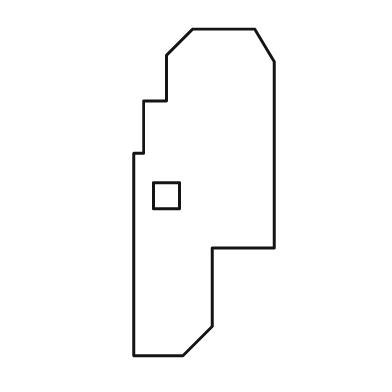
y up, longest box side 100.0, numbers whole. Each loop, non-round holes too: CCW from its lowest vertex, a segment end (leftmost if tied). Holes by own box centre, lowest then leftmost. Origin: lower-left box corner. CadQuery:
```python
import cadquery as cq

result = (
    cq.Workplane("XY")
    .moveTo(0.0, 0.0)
    .lineTo(15.0, 0.0)
    .lineTo(24.0, 9.0)
    .lineTo(24.0, 33.0)
    .lineTo(43.0, 33.0)
    .lineTo(43.0, 90.0)
    .lineTo(37.0, 100.0)
    .lineTo(18.0, 100.0)
    .lineTo(10.0, 92.0)
    .lineTo(10.0, 78.0)
    .lineTo(3.0, 78.0)
    .lineTo(3.0, 62.0)
    .lineTo(0.0, 62.0)
    .close()
    .moveTo(6.0, 45.0)
    .lineTo(14.0, 45.0)
    .lineTo(14.0, 53.0)
    .lineTo(6.0, 53.0)
    .close()
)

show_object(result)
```